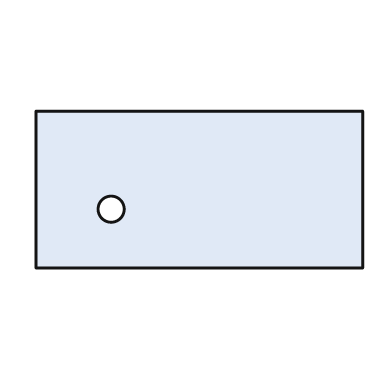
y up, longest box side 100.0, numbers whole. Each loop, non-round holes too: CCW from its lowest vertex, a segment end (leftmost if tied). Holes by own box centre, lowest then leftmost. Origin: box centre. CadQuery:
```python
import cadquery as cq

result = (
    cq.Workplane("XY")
    .moveTo(-50.0, -24.0)
    .lineTo(50.0, -24.0)
    .lineTo(50.0, 24.0)
    .lineTo(-50.0, 24.0)
    .close()
    .moveTo(-27.0, -6.0)
    .circle(4.0)
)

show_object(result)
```